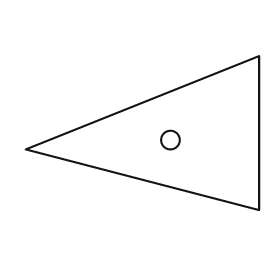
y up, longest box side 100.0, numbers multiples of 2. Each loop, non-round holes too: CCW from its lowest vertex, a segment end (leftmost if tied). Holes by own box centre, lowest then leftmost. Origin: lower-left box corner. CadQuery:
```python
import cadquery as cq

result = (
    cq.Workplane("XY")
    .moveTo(100.0, 0.0)
    .lineTo(100.0, 66.0)
    .lineTo(0.0, 26.0)
    .close()
    .moveTo(62.0, 30.0)
    .circle(4.0)
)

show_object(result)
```